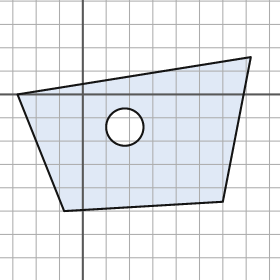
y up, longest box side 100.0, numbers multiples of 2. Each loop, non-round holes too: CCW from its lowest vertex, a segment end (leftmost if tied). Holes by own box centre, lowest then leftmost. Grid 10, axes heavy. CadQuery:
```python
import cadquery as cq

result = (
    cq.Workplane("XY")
    .moveTo(-8.0, -50.0)
    .lineTo(60.0, -46.0)
    .lineTo(72.0, 16.0)
    .lineTo(-28.0, 0.0)
    .close()
    .moveTo(18.0, -14.0)
    .circle(8.0)
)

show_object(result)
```